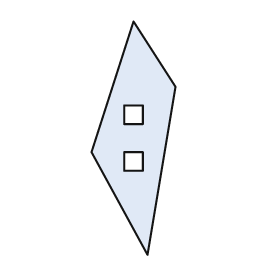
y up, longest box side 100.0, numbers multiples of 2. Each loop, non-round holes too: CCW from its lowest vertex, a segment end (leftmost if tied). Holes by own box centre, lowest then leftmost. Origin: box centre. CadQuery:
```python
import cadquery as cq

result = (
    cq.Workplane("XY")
    .moveTo(6.0, -50.0)
    .lineTo(18.0, 22.0)
    .lineTo(0.0, 50.0)
    .lineTo(-18.0, -6.0)
    .close()
    .moveTo(-4.0, -14.0)
    .lineTo(4.0, -14.0)
    .lineTo(4.0, -6.0)
    .lineTo(-4.0, -6.0)
    .close()
    .moveTo(-4.0, 6.0)
    .lineTo(4.0, 6.0)
    .lineTo(4.0, 14.0)
    .lineTo(-4.0, 14.0)
    .close()
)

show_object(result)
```